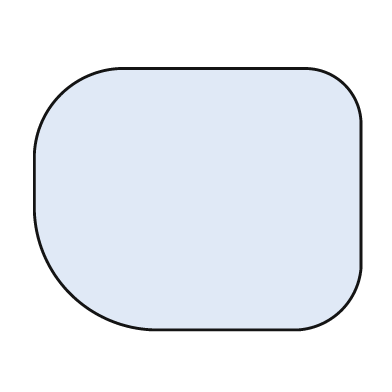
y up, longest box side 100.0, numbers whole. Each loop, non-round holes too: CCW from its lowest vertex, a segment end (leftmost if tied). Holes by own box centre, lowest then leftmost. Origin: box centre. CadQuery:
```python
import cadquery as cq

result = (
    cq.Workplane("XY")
    .moveTo(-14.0, -40.0)
    .lineTo(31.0, -40.0)
    .threePointArc((44.0, -34.0), (50.0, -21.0))
    .lineTo(50.0, 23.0)
    .threePointArc((45.0, 35.0), (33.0, 40.0))
    .lineTo(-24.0, 40.0)
    .threePointArc((-42.0, 32.0), (-50.0, 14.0))
    .lineTo(-50.0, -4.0)
    .threePointArc((-39.0, -29.0), (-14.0, -40.0))
    .close()
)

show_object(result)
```